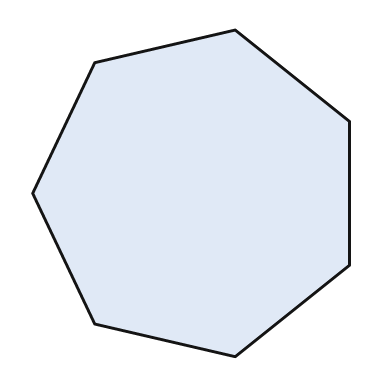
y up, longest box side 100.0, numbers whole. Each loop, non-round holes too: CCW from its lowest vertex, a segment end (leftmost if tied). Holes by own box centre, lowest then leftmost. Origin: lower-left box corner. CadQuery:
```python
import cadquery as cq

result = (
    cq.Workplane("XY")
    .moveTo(62.0, 0.0)
    .lineTo(97.0, 28.0)
    .lineTo(97.0, 72.0)
    .lineTo(62.0, 100.0)
    .lineTo(19.0, 90.0)
    .lineTo(0.0, 50.0)
    .lineTo(19.0, 10.0)
    .close()
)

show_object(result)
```